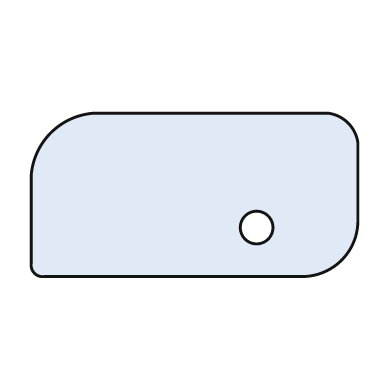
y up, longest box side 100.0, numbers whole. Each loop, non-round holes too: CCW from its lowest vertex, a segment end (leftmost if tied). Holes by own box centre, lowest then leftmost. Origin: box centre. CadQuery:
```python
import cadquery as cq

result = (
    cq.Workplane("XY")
    .moveTo(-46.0, -25.0)
    .lineTo(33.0, -25.0)
    .threePointArc((45.0, -20.0), (50.0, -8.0))
    .lineTo(50.0, 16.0)
    .threePointArc((47.0, 22.0), (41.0, 25.0))
    .lineTo(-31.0, 25.0)
    .threePointArc((-44.0, 19.0), (-50.0, 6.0))
    .lineTo(-50.0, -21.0)
    .threePointArc((-49.0, -24.0), (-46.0, -25.0))
    .close()
    .moveTo(19.0, -10.0)
    .circle(5.0)
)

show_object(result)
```